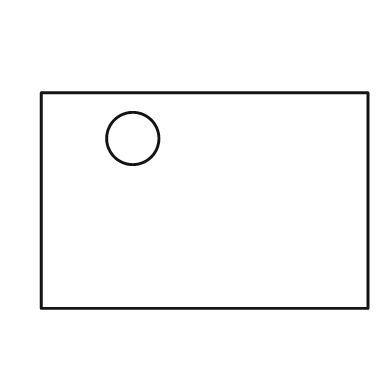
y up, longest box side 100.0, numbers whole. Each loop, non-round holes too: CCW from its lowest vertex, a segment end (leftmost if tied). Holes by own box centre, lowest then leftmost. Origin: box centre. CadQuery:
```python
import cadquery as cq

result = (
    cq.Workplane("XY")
    .moveTo(-50.0, -33.0)
    .lineTo(50.0, -33.0)
    .lineTo(50.0, 33.0)
    .lineTo(-50.0, 33.0)
    .close()
    .moveTo(-22.0, 19.0)
    .circle(8.0)
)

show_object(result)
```